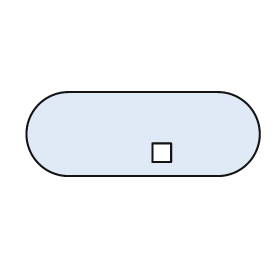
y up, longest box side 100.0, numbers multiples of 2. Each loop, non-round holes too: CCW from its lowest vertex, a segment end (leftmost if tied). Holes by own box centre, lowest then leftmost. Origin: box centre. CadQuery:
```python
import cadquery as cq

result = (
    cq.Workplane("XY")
    .moveTo(-32.0, -18.0)
    .lineTo(32.0, -18.0)
    .threePointArc((50.0, 0.0), (32.0, 18.0))
    .lineTo(-32.0, 18.0)
    .threePointArc((-50.0, 0.0), (-32.0, -18.0))
    .close()
    .moveTo(4.0, -12.0)
    .lineTo(12.0, -12.0)
    .lineTo(12.0, -4.0)
    .lineTo(4.0, -4.0)
    .close()
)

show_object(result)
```